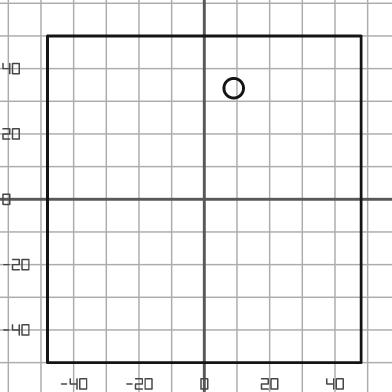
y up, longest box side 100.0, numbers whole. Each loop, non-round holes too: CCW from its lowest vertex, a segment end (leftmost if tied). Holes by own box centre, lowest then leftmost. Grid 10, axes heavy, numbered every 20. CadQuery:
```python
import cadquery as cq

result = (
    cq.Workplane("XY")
    .moveTo(-48.0, -50.0)
    .lineTo(48.0, -50.0)
    .lineTo(48.0, 50.0)
    .lineTo(-48.0, 50.0)
    .close()
    .moveTo(9.0, 34.0)
    .circle(3.0)
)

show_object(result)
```